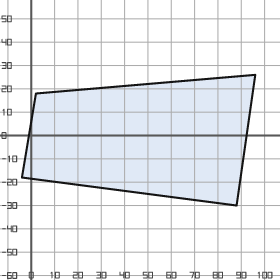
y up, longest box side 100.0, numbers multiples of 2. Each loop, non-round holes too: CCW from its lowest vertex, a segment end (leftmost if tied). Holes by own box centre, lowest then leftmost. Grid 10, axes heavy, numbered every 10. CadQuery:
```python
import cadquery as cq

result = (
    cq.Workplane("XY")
    .moveTo(88.0, -30.0)
    .lineTo(96.0, 26.0)
    .lineTo(2.0, 18.0)
    .lineTo(-4.0, -18.0)
    .close()
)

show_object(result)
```